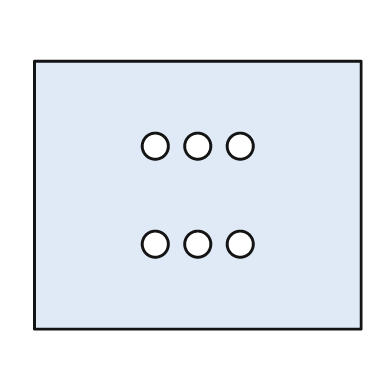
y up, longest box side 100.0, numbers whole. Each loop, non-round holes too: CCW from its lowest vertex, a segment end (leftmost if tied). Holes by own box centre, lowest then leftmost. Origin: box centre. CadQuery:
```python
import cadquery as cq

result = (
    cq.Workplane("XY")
    .moveTo(-50.0, -41.0)
    .lineTo(50.0, -41.0)
    .lineTo(50.0, 41.0)
    .lineTo(-50.0, 41.0)
    .close()
    .moveTo(-13.0, -15.0)
    .circle(4.0)
    .moveTo(0.0, -15.0)
    .circle(4.0)
    .moveTo(13.0, -15.0)
    .circle(4.0)
    .moveTo(-13.0, 15.0)
    .circle(4.0)
    .moveTo(0.0, 15.0)
    .circle(4.0)
    .moveTo(13.0, 15.0)
    .circle(4.0)
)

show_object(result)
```